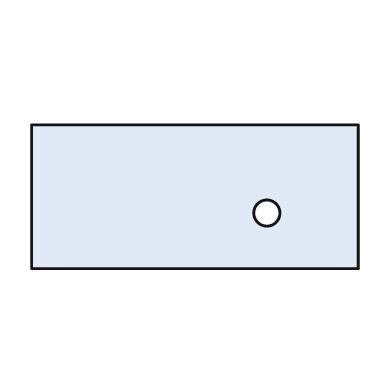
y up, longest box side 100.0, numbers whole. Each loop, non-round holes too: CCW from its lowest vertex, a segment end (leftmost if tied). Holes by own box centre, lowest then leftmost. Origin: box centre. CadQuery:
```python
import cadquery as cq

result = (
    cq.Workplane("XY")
    .moveTo(-50.0, -22.0)
    .lineTo(50.0, -22.0)
    .lineTo(50.0, 22.0)
    .lineTo(-50.0, 22.0)
    .close()
    .moveTo(22.0, -5.0)
    .circle(4.0)
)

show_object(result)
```